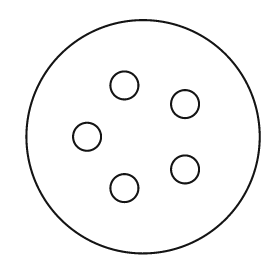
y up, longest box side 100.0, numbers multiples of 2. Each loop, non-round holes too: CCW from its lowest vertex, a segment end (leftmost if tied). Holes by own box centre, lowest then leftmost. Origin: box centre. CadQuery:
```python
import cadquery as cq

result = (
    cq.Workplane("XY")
    .moveTo(0.0, 0.0)
    .circle(50.0)
    .moveTo(-8.0, -22.0)
    .circle(6.0)
    .moveTo(18.0, -14.0)
    .circle(6.0)
    .moveTo(-24.0, 0.0)
    .circle(6.0)
    .moveTo(18.0, 14.0)
    .circle(6.0)
    .moveTo(-8.0, 22.0)
    .circle(6.0)
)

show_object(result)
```